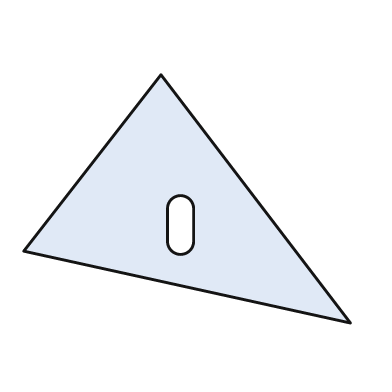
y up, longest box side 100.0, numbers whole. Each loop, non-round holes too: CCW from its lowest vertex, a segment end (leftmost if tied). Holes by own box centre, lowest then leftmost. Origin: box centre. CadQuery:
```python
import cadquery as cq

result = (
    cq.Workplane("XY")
    .moveTo(50.0, -38.0)
    .lineTo(-8.0, 38.0)
    .lineTo(-50.0, -16.0)
    .close()
    .moveTo(-6.0, -13.0)
    .threePointArc((-2.0, -17.0), (2.0, -13.0))
    .lineTo(2.0, -3.0)
    .threePointArc((-2.0, 1.0), (-6.0, -3.0))
    .close()
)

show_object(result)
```